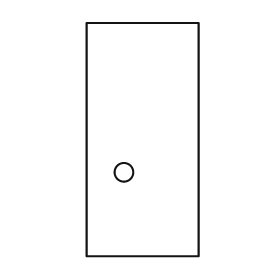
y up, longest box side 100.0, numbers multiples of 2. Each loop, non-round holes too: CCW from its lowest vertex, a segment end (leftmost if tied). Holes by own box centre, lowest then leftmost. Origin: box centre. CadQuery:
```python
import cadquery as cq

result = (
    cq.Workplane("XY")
    .moveTo(-24.0, -50.0)
    .lineTo(24.0, -50.0)
    .lineTo(24.0, 50.0)
    .lineTo(-24.0, 50.0)
    .close()
    .moveTo(-8.0, -14.0)
    .circle(4.0)
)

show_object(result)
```